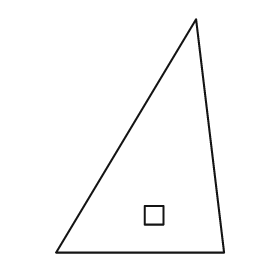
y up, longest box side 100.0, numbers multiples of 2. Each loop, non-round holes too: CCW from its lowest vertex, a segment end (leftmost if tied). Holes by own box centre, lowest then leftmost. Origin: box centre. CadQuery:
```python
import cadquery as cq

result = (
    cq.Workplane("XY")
    .moveTo(-36.0, -50.0)
    .lineTo(36.0, -50.0)
    .lineTo(24.0, 50.0)
    .close()
    .moveTo(2.0, -38.0)
    .lineTo(10.0, -38.0)
    .lineTo(10.0, -30.0)
    .lineTo(2.0, -30.0)
    .close()
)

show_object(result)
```